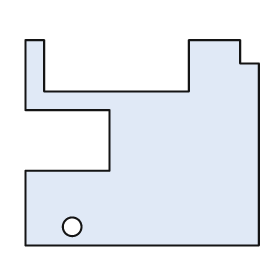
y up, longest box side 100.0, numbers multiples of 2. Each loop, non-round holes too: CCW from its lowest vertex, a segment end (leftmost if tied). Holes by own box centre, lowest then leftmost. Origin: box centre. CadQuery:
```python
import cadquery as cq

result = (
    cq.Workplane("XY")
    .moveTo(-50.0, -44.0)
    .lineTo(50.0, -44.0)
    .lineTo(50.0, 34.0)
    .lineTo(42.0, 34.0)
    .lineTo(42.0, 44.0)
    .lineTo(20.0, 44.0)
    .lineTo(20.0, 22.0)
    .lineTo(-42.0, 22.0)
    .lineTo(-42.0, 44.0)
    .lineTo(-50.0, 44.0)
    .lineTo(-50.0, 14.0)
    .lineTo(-14.0, 14.0)
    .lineTo(-14.0, -12.0)
    .lineTo(-50.0, -12.0)
    .close()
    .moveTo(-30.0, -36.0)
    .circle(4.0)
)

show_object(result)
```